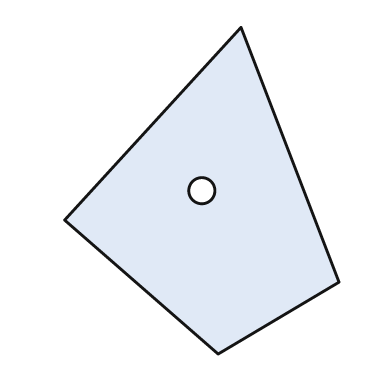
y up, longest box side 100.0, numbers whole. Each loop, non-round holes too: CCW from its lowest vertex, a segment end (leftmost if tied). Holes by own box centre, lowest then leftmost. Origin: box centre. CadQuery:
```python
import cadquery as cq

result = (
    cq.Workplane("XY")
    .moveTo(5.0, -50.0)
    .lineTo(42.0, -28.0)
    .lineTo(12.0, 50.0)
    .lineTo(-42.0, -9.0)
    .close()
    .moveTo(0.0, 0.0)
    .circle(4.0)
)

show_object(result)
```